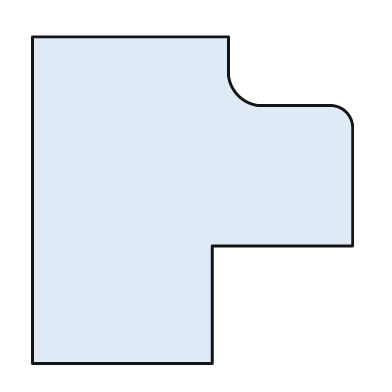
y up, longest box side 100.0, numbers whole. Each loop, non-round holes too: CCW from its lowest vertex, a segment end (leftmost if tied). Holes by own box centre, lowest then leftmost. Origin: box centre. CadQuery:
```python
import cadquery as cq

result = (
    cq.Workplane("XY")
    .moveTo(-49.0, -50.0)
    .lineTo(6.0, -50.0)
    .lineTo(6.0, -14.0)
    .lineTo(49.0, -14.0)
    .lineTo(49.0, 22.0)
    .threePointArc((47.0, 27.0), (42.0, 29.0))
    .lineTo(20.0, 29.0)
    .threePointArc((14.0, 32.0), (11.0, 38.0))
    .lineTo(11.0, 50.0)
    .lineTo(-49.0, 50.0)
    .close()
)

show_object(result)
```